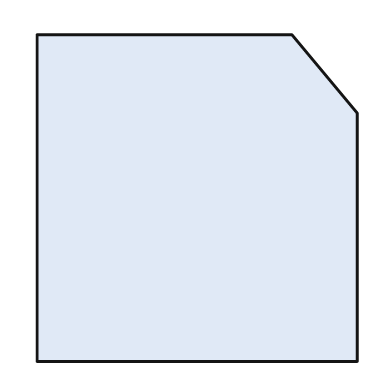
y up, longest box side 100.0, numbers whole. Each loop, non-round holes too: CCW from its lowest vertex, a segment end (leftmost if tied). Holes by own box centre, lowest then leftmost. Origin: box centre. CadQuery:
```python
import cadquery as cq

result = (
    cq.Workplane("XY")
    .moveTo(-49.0, -50.0)
    .lineTo(49.0, -50.0)
    .lineTo(49.0, 26.0)
    .lineTo(29.0, 50.0)
    .lineTo(-49.0, 50.0)
    .close()
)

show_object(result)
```